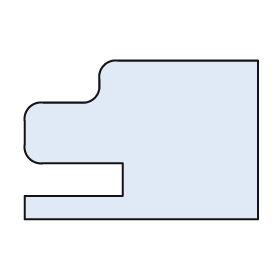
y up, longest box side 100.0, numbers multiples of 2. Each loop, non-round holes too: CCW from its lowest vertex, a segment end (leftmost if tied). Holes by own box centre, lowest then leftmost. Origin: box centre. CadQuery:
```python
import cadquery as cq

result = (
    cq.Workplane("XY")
    .moveTo(-50.0, -34.0)
    .lineTo(50.0, -34.0)
    .lineTo(50.0, 34.0)
    .lineTo(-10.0, 34.0)
    .threePointArc((-16.0, 32.0), (-18.0, 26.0))
    .lineTo(-18.0, 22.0)
    .threePointArc((-20.0, 18.0), (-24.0, 16.0))
    .lineTo(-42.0, 16.0)
    .threePointArc((-48.0, 14.0), (-50.0, 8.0))
    .lineTo(-50.0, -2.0)
    .threePointArc((-48.0, -8.0), (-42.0, -10.0))
    .lineTo(-8.0, -10.0)
    .lineTo(-8.0, -24.0)
    .lineTo(-50.0, -24.0)
    .close()
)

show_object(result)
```